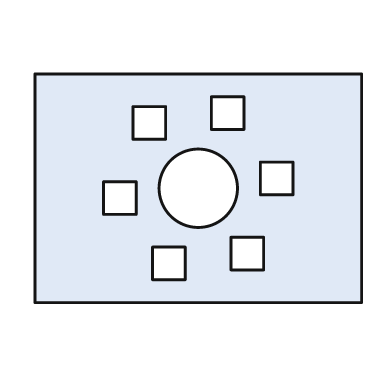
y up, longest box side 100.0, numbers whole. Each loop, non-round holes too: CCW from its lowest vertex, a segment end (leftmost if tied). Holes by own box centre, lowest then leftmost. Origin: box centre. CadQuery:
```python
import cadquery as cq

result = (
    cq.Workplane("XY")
    .moveTo(-50.0, -35.0)
    .lineTo(50.0, -35.0)
    .lineTo(50.0, 35.0)
    .lineTo(-50.0, 35.0)
    .close()
    .moveTo(-14.0, -28.0)
    .lineTo(-4.0, -28.0)
    .lineTo(-4.0, -18.0)
    .lineTo(-14.0, -18.0)
    .close()
    .moveTo(10.0, -25.0)
    .lineTo(20.0, -25.0)
    .lineTo(20.0, -15.0)
    .lineTo(10.0, -15.0)
    .close()
    .moveTo(-29.0, -8.0)
    .lineTo(-19.0, -8.0)
    .lineTo(-19.0, 2.0)
    .lineTo(-29.0, 2.0)
    .close()
    .moveTo(0.0, 0.0)
    .circle(12.0)
    .moveTo(19.0, -2.0)
    .lineTo(29.0, -2.0)
    .lineTo(29.0, 8.0)
    .lineTo(19.0, 8.0)
    .close()
    .moveTo(-20.0, 15.0)
    .lineTo(-10.0, 15.0)
    .lineTo(-10.0, 25.0)
    .lineTo(-20.0, 25.0)
    .close()
    .moveTo(4.0, 18.0)
    .lineTo(14.0, 18.0)
    .lineTo(14.0, 28.0)
    .lineTo(4.0, 28.0)
    .close()
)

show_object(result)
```